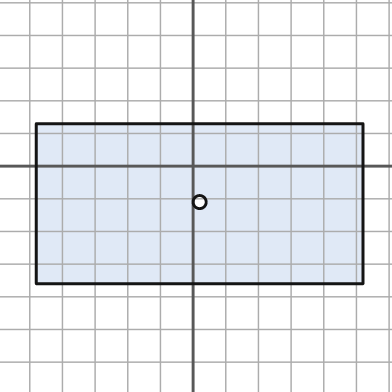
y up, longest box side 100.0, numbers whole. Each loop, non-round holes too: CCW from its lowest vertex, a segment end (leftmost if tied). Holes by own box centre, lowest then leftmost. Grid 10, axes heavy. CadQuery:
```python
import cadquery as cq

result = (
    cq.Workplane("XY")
    .moveTo(-48.0, -36.0)
    .lineTo(52.0, -36.0)
    .lineTo(52.0, 13.0)
    .lineTo(-48.0, 13.0)
    .close()
    .moveTo(2.0, -11.0)
    .circle(2.0)
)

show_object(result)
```